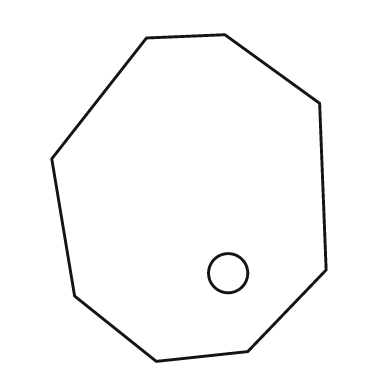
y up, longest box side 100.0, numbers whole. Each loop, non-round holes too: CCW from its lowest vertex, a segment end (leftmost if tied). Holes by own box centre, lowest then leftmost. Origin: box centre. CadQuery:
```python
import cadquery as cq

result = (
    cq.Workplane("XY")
    .moveTo(-10.0, -50.0)
    .lineTo(18.0, -47.0)
    .lineTo(42.0, -22.0)
    .lineTo(40.0, 29.0)
    .lineTo(11.0, 50.0)
    .lineTo(-13.0, 49.0)
    .lineTo(-42.0, 12.0)
    .lineTo(-35.0, -30.0)
    .close()
    .moveTo(12.0, -23.0)
    .circle(6.0)
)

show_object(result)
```